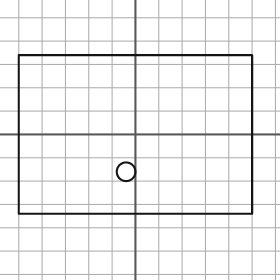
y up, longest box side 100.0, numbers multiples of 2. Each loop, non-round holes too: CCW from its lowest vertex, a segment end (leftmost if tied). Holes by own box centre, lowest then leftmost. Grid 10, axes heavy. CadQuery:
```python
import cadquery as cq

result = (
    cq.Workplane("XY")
    .moveTo(-50.0, -34.0)
    .lineTo(50.0, -34.0)
    .lineTo(50.0, 34.0)
    .lineTo(-50.0, 34.0)
    .close()
    .moveTo(-4.0, -16.0)
    .circle(4.0)
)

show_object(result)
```